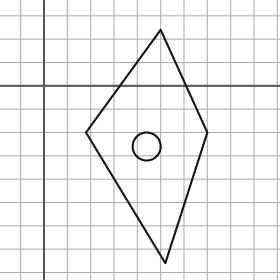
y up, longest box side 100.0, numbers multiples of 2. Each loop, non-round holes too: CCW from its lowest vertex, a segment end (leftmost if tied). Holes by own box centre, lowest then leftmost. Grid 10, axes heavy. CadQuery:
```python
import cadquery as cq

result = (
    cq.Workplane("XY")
    .moveTo(52.0, -76.0)
    .lineTo(70.0, -20.0)
    .lineTo(50.0, 24.0)
    .lineTo(18.0, -20.0)
    .close()
    .moveTo(44.0, -26.0)
    .circle(6.0)
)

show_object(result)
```